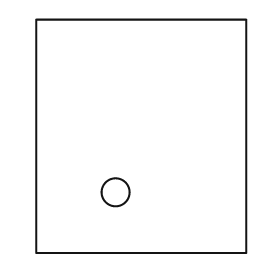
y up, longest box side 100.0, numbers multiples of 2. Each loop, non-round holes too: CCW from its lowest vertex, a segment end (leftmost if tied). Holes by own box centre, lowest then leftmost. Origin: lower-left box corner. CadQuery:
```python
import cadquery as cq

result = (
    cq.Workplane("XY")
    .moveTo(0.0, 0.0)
    .lineTo(90.0, 0.0)
    .lineTo(90.0, 100.0)
    .lineTo(0.0, 100.0)
    .close()
    .moveTo(34.0, 26.0)
    .circle(6.0)
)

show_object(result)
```